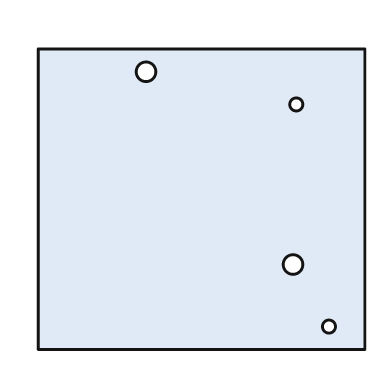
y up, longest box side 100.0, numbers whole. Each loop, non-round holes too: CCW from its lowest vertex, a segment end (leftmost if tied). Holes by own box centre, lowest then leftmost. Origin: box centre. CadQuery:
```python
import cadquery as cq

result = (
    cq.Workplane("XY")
    .moveTo(-50.0, -46.0)
    .lineTo(50.0, -46.0)
    .lineTo(50.0, 46.0)
    .lineTo(-50.0, 46.0)
    .close()
    .moveTo(39.0, -39.0)
    .circle(2.0)
    .moveTo(28.0, -20.0)
    .circle(3.0)
    .moveTo(29.0, 29.0)
    .circle(2.0)
    .moveTo(-17.0, 39.0)
    .circle(3.0)
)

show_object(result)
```